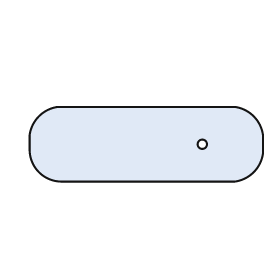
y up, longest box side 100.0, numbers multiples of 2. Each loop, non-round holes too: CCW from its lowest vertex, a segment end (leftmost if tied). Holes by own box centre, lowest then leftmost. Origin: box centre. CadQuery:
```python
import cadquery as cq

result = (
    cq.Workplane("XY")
    .moveTo(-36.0, -16.0)
    .lineTo(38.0, -16.0)
    .threePointArc((46.0, -12.0), (50.0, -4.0))
    .lineTo(50.0, 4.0)
    .threePointArc((46.0, 12.0), (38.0, 16.0))
    .lineTo(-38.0, 16.0)
    .threePointArc((-46.0, 12.0), (-50.0, 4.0))
    .lineTo(-50.0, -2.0)
    .threePointArc((-46.0, -12.0), (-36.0, -16.0))
    .close()
    .moveTo(24.0, 0.0)
    .circle(2.0)
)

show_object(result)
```